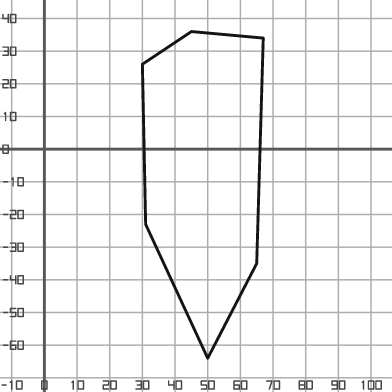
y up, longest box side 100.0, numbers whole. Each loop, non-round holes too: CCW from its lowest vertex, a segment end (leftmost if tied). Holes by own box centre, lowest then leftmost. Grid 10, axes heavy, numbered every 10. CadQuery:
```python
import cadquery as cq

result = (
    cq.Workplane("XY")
    .moveTo(50.0, -64.0)
    .lineTo(65.0, -35.0)
    .lineTo(67.0, 34.0)
    .lineTo(45.0, 36.0)
    .lineTo(30.0, 26.0)
    .lineTo(31.0, -23.0)
    .close()
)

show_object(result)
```